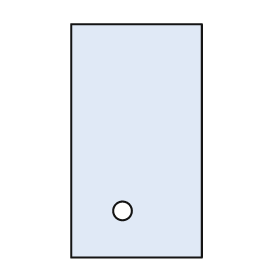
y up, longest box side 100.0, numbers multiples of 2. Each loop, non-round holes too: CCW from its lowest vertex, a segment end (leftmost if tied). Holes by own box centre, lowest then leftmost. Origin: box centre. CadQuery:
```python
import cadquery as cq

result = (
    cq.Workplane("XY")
    .moveTo(-28.0, -50.0)
    .lineTo(28.0, -50.0)
    .lineTo(28.0, 50.0)
    .lineTo(-28.0, 50.0)
    .close()
    .moveTo(-6.0, -30.0)
    .circle(4.0)
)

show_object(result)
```